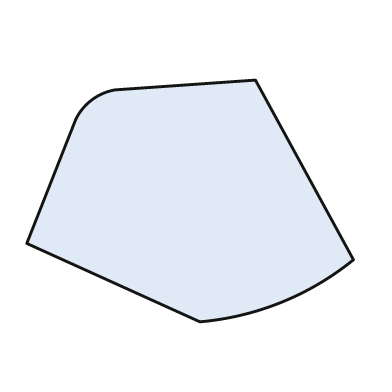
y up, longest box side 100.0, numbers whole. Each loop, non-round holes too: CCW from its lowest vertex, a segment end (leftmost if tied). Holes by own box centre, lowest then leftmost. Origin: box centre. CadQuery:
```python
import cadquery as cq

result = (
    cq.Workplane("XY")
    .moveTo(3.0, -37.0)
    .threePointArc((28.0, -31.0), (50.0, -18.0))
    .lineTo(20.0, 37.0)
    .lineTo(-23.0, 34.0)
    .threePointArc((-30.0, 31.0), (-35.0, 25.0))
    .lineTo(-50.0, -13.0)
    .close()
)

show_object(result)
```